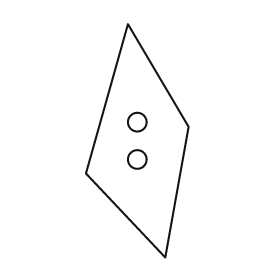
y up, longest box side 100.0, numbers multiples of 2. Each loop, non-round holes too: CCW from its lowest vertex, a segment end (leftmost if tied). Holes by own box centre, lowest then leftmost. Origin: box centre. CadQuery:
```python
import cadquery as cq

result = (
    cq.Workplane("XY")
    .moveTo(12.0, -50.0)
    .lineTo(22.0, 6.0)
    .lineTo(-4.0, 50.0)
    .lineTo(-22.0, -14.0)
    .close()
    .moveTo(0.0, -8.0)
    .circle(4.0)
    .moveTo(0.0, 8.0)
    .circle(4.0)
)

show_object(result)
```